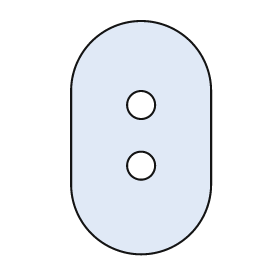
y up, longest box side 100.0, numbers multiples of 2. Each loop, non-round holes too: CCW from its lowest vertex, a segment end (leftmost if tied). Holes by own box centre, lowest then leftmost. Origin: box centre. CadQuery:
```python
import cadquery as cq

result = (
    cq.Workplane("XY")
    .moveTo(-30.0, -20.0)
    .threePointArc((0.0, -50.0), (30.0, -20.0))
    .lineTo(30.0, 20.0)
    .threePointArc((0.0, 50.0), (-30.0, 20.0))
    .close()
    .moveTo(0.0, -12.0)
    .circle(6.0)
    .moveTo(0.0, 14.0)
    .circle(6.0)
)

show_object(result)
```